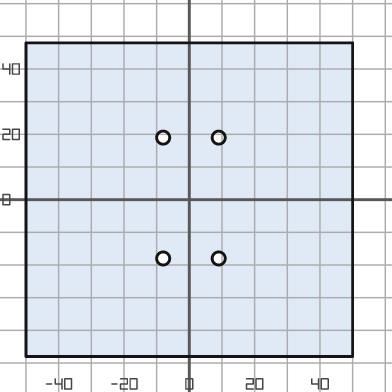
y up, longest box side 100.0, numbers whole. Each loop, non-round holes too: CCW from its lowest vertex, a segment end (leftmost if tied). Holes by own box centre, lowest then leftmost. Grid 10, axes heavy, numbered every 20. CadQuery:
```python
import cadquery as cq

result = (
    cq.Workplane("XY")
    .moveTo(-50.0, -48.0)
    .lineTo(50.0, -48.0)
    .lineTo(50.0, 48.0)
    .lineTo(-50.0, 48.0)
    .close()
    .moveTo(-8.0, -18.0)
    .circle(2.0)
    .moveTo(9.0, -18.0)
    .circle(2.0)
    .moveTo(-8.0, 19.0)
    .circle(2.0)
    .moveTo(9.0, 19.0)
    .circle(2.0)
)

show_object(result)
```